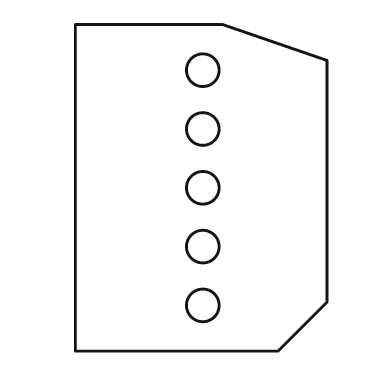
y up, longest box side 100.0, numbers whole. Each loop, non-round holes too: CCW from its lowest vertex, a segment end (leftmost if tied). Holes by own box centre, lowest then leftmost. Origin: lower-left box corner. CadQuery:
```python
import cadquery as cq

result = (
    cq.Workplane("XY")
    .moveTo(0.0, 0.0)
    .lineTo(62.0, 0.0)
    .lineTo(77.0, 15.0)
    .lineTo(77.0, 89.0)
    .lineTo(45.0, 100.0)
    .lineTo(0.0, 100.0)
    .close()
    .moveTo(39.0, 14.0)
    .circle(5.0)
    .moveTo(39.0, 32.0)
    .circle(5.0)
    .moveTo(39.0, 50.0)
    .circle(5.0)
    .moveTo(39.0, 68.0)
    .circle(5.0)
    .moveTo(39.0, 86.0)
    .circle(5.0)
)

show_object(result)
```